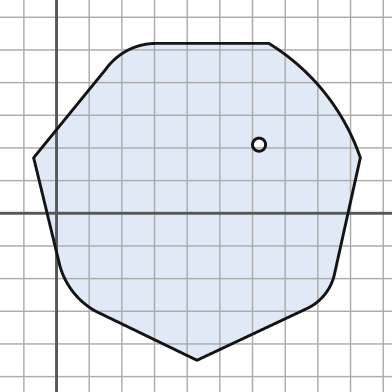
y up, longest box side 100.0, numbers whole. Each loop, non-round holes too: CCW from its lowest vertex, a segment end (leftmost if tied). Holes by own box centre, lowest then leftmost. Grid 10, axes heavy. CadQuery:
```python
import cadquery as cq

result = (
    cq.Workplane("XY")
    .moveTo(43.0, -45.0)
    .lineTo(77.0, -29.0)
    .threePointArc((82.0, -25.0), (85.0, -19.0))
    .lineTo(93.0, 17.0)
    .threePointArc((82.0, 37.0), (65.0, 52.0))
    .lineTo(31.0, 52.0)
    .threePointArc((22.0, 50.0), (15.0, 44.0))
    .lineTo(-7.0, 17.0)
    .lineTo(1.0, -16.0)
    .threePointArc((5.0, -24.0), (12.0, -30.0))
    .close()
    .moveTo(62.0, 21.0)
    .circle(2.0)
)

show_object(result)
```